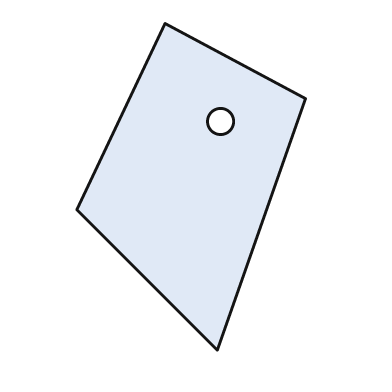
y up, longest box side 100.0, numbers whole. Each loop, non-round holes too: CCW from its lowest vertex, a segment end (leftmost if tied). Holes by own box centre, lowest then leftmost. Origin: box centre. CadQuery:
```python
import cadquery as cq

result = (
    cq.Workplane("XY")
    .moveTo(8.0, -50.0)
    .lineTo(35.0, 27.0)
    .lineTo(-8.0, 50.0)
    .lineTo(-35.0, -7.0)
    .close()
    .moveTo(9.0, 20.0)
    .circle(4.0)
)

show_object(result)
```